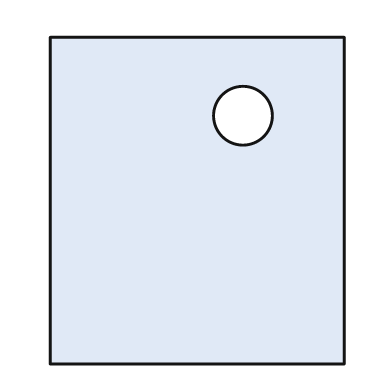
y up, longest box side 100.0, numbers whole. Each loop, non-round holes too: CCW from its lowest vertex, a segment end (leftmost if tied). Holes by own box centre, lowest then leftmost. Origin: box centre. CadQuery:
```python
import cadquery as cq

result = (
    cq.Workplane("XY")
    .moveTo(-45.0, -50.0)
    .lineTo(45.0, -50.0)
    .lineTo(45.0, 50.0)
    .lineTo(-45.0, 50.0)
    .close()
    .moveTo(14.0, 26.0)
    .circle(9.0)
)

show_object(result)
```